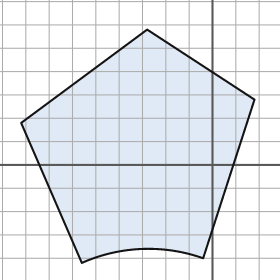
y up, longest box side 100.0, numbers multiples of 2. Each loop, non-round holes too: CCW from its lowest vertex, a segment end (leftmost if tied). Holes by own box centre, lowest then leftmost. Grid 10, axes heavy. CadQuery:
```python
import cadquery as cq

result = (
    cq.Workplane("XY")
    .moveTo(-56.0, -42.0)
    .threePointArc((-30.0, -36.0), (-4.0, -40.0))
    .lineTo(18.0, 28.0)
    .lineTo(-28.0, 58.0)
    .lineTo(-82.0, 18.0)
    .close()
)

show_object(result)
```